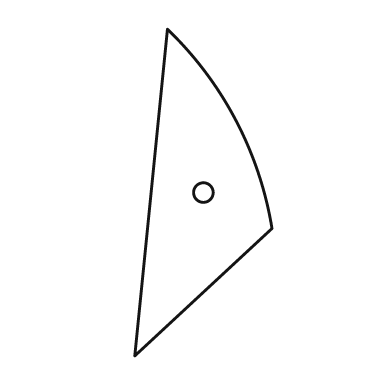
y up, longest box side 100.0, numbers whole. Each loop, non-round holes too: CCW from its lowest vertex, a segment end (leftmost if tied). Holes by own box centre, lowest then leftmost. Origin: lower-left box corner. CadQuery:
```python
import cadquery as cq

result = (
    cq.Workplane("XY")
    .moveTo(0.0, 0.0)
    .lineTo(42.0, 39.0)
    .threePointArc((31.0, 72.0), (10.0, 100.0))
    .close()
    .moveTo(21.0, 50.0)
    .circle(3.0)
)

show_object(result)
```